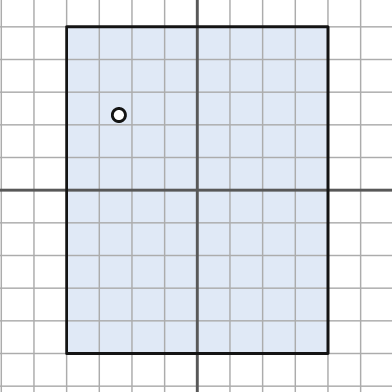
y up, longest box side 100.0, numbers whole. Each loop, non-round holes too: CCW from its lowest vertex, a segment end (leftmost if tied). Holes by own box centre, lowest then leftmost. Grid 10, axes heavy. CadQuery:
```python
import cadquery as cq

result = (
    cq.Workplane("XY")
    .moveTo(-40.0, -50.0)
    .lineTo(40.0, -50.0)
    .lineTo(40.0, 50.0)
    .lineTo(-40.0, 50.0)
    .close()
    .moveTo(-24.0, 23.0)
    .circle(2.0)
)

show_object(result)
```